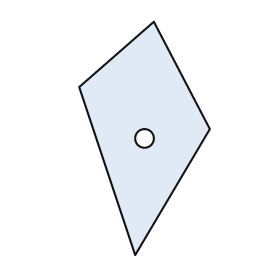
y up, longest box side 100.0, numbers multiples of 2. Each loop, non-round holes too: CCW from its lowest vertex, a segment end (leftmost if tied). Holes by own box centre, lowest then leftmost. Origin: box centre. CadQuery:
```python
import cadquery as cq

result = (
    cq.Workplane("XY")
    .moveTo(-4.0, -50.0)
    .lineTo(28.0, 4.0)
    .lineTo(4.0, 50.0)
    .lineTo(-28.0, 22.0)
    .close()
    .moveTo(0.0, 0.0)
    .circle(4.0)
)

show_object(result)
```